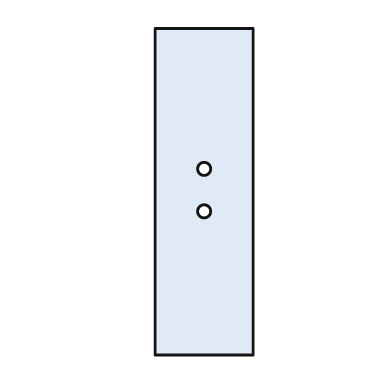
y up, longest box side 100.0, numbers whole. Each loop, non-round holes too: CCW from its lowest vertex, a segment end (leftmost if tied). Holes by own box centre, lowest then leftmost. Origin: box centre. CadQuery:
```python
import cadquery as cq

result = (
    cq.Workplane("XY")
    .moveTo(-15.0, -50.0)
    .lineTo(15.0, -50.0)
    .lineTo(15.0, 50.0)
    .lineTo(-15.0, 50.0)
    .close()
    .moveTo(0.0, -6.0)
    .circle(2.0)
    .moveTo(0.0, 7.0)
    .circle(2.0)
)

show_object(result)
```